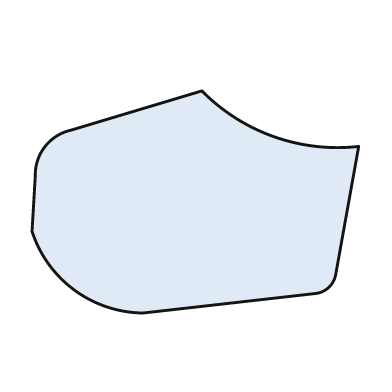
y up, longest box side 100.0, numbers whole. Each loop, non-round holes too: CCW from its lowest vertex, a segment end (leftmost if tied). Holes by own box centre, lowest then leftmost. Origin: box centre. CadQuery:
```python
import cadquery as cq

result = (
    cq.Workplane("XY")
    .moveTo(-16.0, -34.0)
    .lineTo(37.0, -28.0)
    .threePointArc((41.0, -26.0), (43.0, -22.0))
    .lineTo(50.0, 17.0)
    .threePointArc((24.0, 20.0), (2.0, 34.0))
    .lineTo(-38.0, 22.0)
    .threePointArc((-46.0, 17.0), (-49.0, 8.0))
    .lineTo(-50.0, -9.0)
    .threePointArc((-37.0, -27.0), (-16.0, -34.0))
    .close()
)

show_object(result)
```